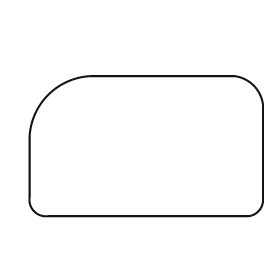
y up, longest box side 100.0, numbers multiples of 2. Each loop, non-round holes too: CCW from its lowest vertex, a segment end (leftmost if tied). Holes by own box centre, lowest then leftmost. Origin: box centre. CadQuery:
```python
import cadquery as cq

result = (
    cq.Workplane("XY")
    .moveTo(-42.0, -30.0)
    .lineTo(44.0, -30.0)
    .threePointArc((48.0, -28.0), (50.0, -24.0))
    .lineTo(50.0, 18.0)
    .threePointArc((46.0, 26.0), (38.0, 30.0))
    .lineTo(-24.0, 30.0)
    .threePointArc((-42.0, 22.0), (-50.0, 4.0))
    .lineTo(-50.0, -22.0)
    .threePointArc((-48.0, -28.0), (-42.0, -30.0))
    .close()
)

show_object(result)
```